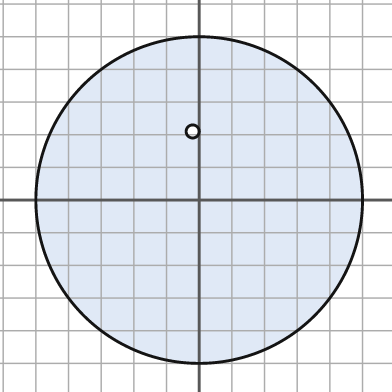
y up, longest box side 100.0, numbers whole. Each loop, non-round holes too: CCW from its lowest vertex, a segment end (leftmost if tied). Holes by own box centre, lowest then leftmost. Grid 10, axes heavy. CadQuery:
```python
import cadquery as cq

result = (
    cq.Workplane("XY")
    .moveTo(0.0, 0.0)
    .circle(50.0)
    .moveTo(-2.0, 21.0)
    .circle(2.0)
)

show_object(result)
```